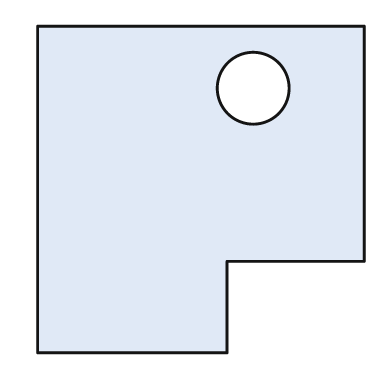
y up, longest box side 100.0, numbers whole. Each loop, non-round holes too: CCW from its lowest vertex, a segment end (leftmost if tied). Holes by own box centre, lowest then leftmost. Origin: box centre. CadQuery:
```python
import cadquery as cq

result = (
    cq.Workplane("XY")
    .moveTo(-50.0, -50.0)
    .lineTo(8.0, -50.0)
    .lineTo(8.0, -22.0)
    .lineTo(50.0, -22.0)
    .lineTo(50.0, 50.0)
    .lineTo(-50.0, 50.0)
    .close()
    .moveTo(16.0, 31.0)
    .circle(11.0)
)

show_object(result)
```